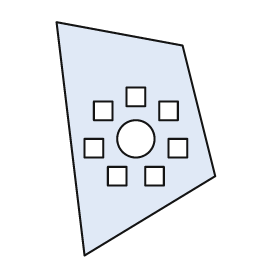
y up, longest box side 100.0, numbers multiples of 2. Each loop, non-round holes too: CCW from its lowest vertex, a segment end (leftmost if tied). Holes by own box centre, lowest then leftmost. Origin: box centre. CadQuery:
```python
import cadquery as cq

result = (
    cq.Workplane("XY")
    .moveTo(-22.0, -50.0)
    .lineTo(34.0, -16.0)
    .lineTo(20.0, 40.0)
    .lineTo(-34.0, 50.0)
    .close()
    .moveTo(-12.0, -20.0)
    .lineTo(-4.0, -20.0)
    .lineTo(-4.0, -12.0)
    .lineTo(-12.0, -12.0)
    .close()
    .moveTo(4.0, -20.0)
    .lineTo(12.0, -20.0)
    .lineTo(12.0, -12.0)
    .lineTo(4.0, -12.0)
    .close()
    .moveTo(-22.0, -8.0)
    .lineTo(-14.0, -8.0)
    .lineTo(-14.0, 0.0)
    .lineTo(-22.0, 0.0)
    .close()
    .moveTo(14.0, -8.0)
    .lineTo(22.0, -8.0)
    .lineTo(22.0, 0.0)
    .lineTo(14.0, 0.0)
    .close()
    .moveTo(0.0, 0.0)
    .circle(8.0)
    .moveTo(-18.0, 8.0)
    .lineTo(-10.0, 8.0)
    .lineTo(-10.0, 16.0)
    .lineTo(-18.0, 16.0)
    .close()
    .moveTo(10.0, 8.0)
    .lineTo(18.0, 8.0)
    .lineTo(18.0, 16.0)
    .lineTo(10.0, 16.0)
    .close()
    .moveTo(-4.0, 14.0)
    .lineTo(4.0, 14.0)
    .lineTo(4.0, 22.0)
    .lineTo(-4.0, 22.0)
    .close()
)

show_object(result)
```